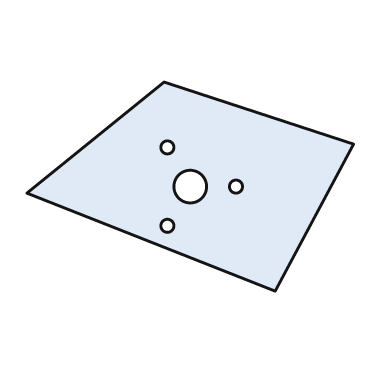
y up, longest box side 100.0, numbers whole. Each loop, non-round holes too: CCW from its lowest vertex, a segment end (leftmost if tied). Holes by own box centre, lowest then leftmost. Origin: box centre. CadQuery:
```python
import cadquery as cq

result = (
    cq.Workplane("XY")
    .moveTo(26.0, -32.0)
    .lineTo(50.0, 13.0)
    .lineTo(-8.0, 32.0)
    .lineTo(-50.0, -2.0)
    .close()
    .moveTo(-7.0, -12.0)
    .circle(2.0)
    .moveTo(0.0, 0.0)
    .circle(5.0)
    .moveTo(14.0, 0.0)
    .circle(2.0)
    .moveTo(-7.0, 12.0)
    .circle(2.0)
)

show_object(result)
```